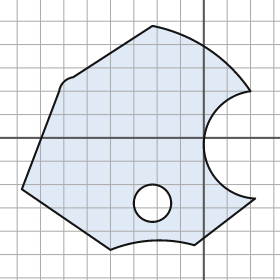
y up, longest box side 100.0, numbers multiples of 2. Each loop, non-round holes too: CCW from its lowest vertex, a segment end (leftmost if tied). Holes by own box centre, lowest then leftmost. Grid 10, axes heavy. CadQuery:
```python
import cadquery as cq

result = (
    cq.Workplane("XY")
    .moveTo(-40.0, -48.0)
    .threePointArc((-22.0, -44.0), (-4.0, -46.0))
    .lineTo(22.0, -26.0)
    .threePointArc((0.0, -4.0), (20.0, 20.0))
    .threePointArc((2.0, 38.0), (-22.0, 48.0))
    .lineTo(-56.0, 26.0)
    .threePointArc((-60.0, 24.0), (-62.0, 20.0))
    .lineTo(-78.0, -22.0)
    .close()
    .moveTo(-22.0, -28.0)
    .circle(8.0)
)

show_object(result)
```